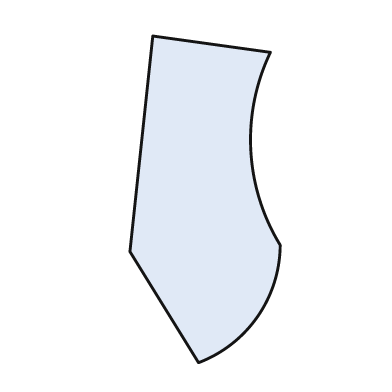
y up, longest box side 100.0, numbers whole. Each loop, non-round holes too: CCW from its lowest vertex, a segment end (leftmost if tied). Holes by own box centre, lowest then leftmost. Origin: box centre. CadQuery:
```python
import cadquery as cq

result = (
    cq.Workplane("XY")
    .moveTo(-2.0, -50.0)
    .threePointArc((16.0, -36.0), (23.0, -14.0))
    .threePointArc((14.0, 15.0), (20.0, 45.0))
    .lineTo(-16.0, 50.0)
    .lineTo(-23.0, -16.0)
    .close()
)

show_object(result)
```